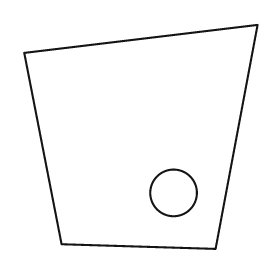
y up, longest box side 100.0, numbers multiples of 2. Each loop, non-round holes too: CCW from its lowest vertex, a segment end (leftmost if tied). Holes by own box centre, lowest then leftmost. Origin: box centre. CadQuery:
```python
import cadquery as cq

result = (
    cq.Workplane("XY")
    .moveTo(32.0, -48.0)
    .lineTo(50.0, 48.0)
    .lineTo(-50.0, 36.0)
    .lineTo(-34.0, -46.0)
    .close()
    .moveTo(14.0, -24.0)
    .circle(10.0)
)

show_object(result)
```